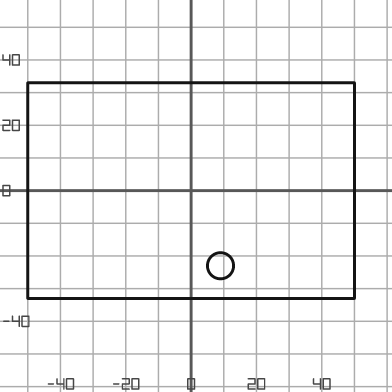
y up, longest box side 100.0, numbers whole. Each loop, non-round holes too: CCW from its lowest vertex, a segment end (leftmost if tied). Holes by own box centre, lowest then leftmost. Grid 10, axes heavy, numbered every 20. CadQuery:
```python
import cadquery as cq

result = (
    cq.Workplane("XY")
    .moveTo(-50.0, -33.0)
    .lineTo(50.0, -33.0)
    .lineTo(50.0, 33.0)
    .lineTo(-50.0, 33.0)
    .close()
    .moveTo(9.0, -23.0)
    .circle(4.0)
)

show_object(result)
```